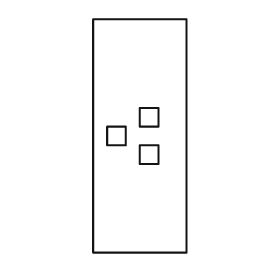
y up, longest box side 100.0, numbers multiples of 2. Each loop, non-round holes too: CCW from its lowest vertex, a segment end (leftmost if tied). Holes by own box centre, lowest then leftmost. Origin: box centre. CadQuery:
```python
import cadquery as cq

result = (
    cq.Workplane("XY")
    .moveTo(-20.0, -50.0)
    .lineTo(20.0, -50.0)
    .lineTo(20.0, 50.0)
    .lineTo(-20.0, 50.0)
    .close()
    .moveTo(0.0, -12.0)
    .lineTo(8.0, -12.0)
    .lineTo(8.0, -4.0)
    .lineTo(0.0, -4.0)
    .close()
    .moveTo(-14.0, -4.0)
    .lineTo(-6.0, -4.0)
    .lineTo(-6.0, 4.0)
    .lineTo(-14.0, 4.0)
    .close()
    .moveTo(0.0, 4.0)
    .lineTo(8.0, 4.0)
    .lineTo(8.0, 12.0)
    .lineTo(0.0, 12.0)
    .close()
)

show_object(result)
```